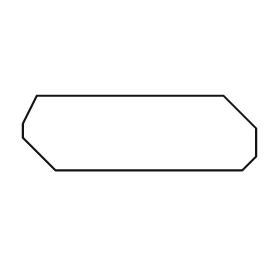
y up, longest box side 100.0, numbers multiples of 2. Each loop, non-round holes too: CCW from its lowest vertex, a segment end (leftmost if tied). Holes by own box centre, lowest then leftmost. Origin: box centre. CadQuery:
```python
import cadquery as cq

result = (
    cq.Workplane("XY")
    .moveTo(-36.0, -16.0)
    .lineTo(44.0, -16.0)
    .lineTo(50.0, -10.0)
    .lineTo(50.0, 2.0)
    .lineTo(36.0, 16.0)
    .lineTo(-44.0, 16.0)
    .lineTo(-50.0, 4.0)
    .lineTo(-50.0, -2.0)
    .close()
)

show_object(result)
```